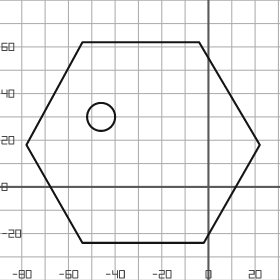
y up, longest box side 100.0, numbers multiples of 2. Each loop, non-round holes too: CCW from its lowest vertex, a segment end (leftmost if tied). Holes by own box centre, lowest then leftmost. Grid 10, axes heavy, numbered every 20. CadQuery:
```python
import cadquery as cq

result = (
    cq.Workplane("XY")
    .moveTo(-54.0, -24.0)
    .lineTo(-2.0, -24.0)
    .lineTo(22.0, 18.0)
    .lineTo(-4.0, 62.0)
    .lineTo(-54.0, 62.0)
    .lineTo(-78.0, 18.0)
    .close()
    .moveTo(-46.0, 30.0)
    .circle(6.0)
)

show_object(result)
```